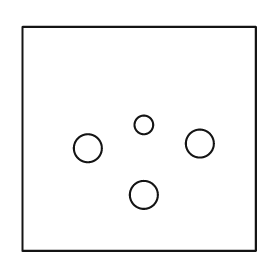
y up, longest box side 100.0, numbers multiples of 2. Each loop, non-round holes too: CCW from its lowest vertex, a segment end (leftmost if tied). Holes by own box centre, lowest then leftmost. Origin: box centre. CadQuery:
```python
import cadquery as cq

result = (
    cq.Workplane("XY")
    .moveTo(-50.0, -48.0)
    .lineTo(50.0, -48.0)
    .lineTo(50.0, 48.0)
    .lineTo(-50.0, 48.0)
    .close()
    .moveTo(2.0, -24.0)
    .circle(6.0)
    .moveTo(-22.0, -4.0)
    .circle(6.0)
    .moveTo(26.0, -2.0)
    .circle(6.0)
    .moveTo(2.0, 6.0)
    .circle(4.0)
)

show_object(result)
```